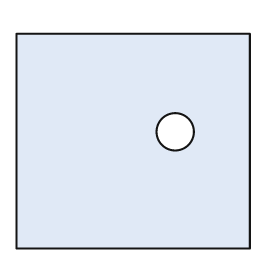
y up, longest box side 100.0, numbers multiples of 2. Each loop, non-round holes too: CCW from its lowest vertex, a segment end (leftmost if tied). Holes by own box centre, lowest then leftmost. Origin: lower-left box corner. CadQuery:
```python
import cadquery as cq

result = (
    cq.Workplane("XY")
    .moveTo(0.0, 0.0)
    .lineTo(100.0, 0.0)
    .lineTo(100.0, 92.0)
    .lineTo(0.0, 92.0)
    .close()
    .moveTo(68.0, 50.0)
    .circle(8.0)
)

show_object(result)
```